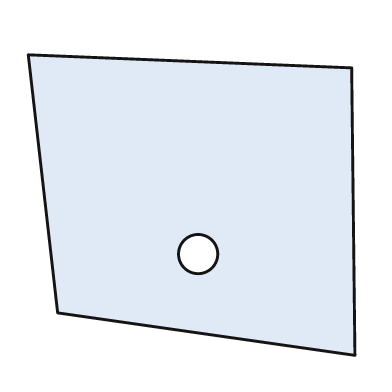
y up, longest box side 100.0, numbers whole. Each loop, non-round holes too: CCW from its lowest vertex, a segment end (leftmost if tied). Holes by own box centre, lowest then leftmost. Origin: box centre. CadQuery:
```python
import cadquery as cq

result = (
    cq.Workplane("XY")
    .moveTo(50.0, -46.0)
    .lineTo(49.0, 42.0)
    .lineTo(-50.0, 46.0)
    .lineTo(-41.0, -33.0)
    .close()
    .moveTo(2.0, -15.0)
    .circle(6.0)
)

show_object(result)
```